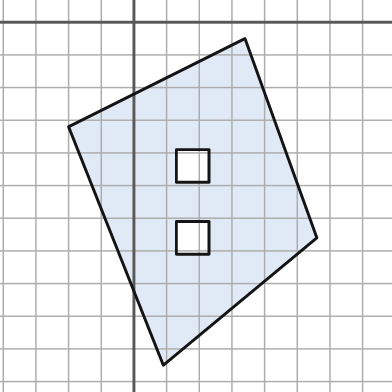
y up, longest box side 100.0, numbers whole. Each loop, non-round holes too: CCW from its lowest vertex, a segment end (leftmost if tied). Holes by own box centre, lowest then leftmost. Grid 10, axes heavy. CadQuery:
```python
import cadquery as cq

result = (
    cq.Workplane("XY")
    .moveTo(9.0, -105.0)
    .lineTo(56.0, -66.0)
    .lineTo(34.0, -5.0)
    .lineTo(-20.0, -32.0)
    .close()
    .moveTo(13.0, -71.0)
    .lineTo(23.0, -71.0)
    .lineTo(23.0, -61.0)
    .lineTo(13.0, -61.0)
    .close()
    .moveTo(13.0, -49.0)
    .lineTo(23.0, -49.0)
    .lineTo(23.0, -39.0)
    .lineTo(13.0, -39.0)
    .close()
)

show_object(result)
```